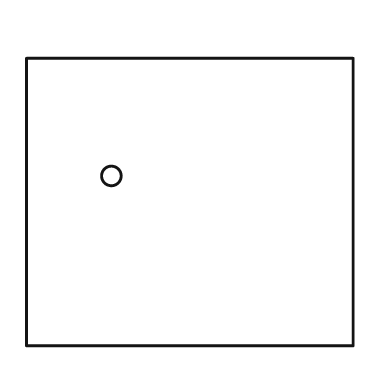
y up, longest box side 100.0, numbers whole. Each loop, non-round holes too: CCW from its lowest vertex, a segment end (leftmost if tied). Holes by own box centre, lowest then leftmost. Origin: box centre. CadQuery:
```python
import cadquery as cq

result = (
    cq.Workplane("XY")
    .moveTo(-50.0, -44.0)
    .lineTo(50.0, -44.0)
    .lineTo(50.0, 44.0)
    .lineTo(-50.0, 44.0)
    .close()
    .moveTo(-24.0, 8.0)
    .circle(3.0)
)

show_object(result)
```